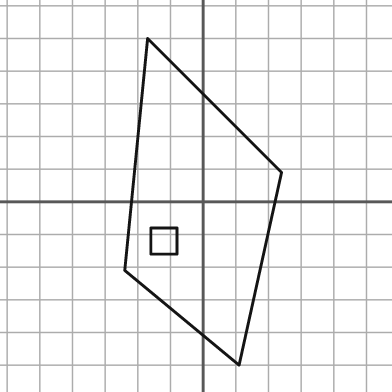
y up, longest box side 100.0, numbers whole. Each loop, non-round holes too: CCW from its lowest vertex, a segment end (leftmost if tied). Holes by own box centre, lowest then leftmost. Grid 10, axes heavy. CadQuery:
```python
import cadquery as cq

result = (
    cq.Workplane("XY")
    .moveTo(11.0, -50.0)
    .lineTo(24.0, 9.0)
    .lineTo(-17.0, 50.0)
    .lineTo(-24.0, -21.0)
    .close()
    .moveTo(-16.0, -16.0)
    .lineTo(-8.0, -16.0)
    .lineTo(-8.0, -8.0)
    .lineTo(-16.0, -8.0)
    .close()
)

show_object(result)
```